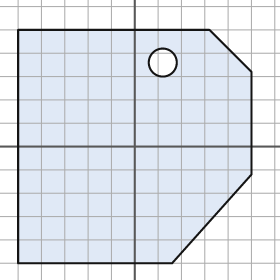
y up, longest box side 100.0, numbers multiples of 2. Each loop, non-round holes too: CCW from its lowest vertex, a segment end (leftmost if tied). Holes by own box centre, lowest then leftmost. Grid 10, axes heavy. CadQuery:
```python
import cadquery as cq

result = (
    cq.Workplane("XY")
    .moveTo(-50.0, -50.0)
    .lineTo(16.0, -50.0)
    .lineTo(50.0, -12.0)
    .lineTo(50.0, 32.0)
    .lineTo(32.0, 50.0)
    .lineTo(-50.0, 50.0)
    .close()
    .moveTo(12.0, 36.0)
    .circle(6.0)
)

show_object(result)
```